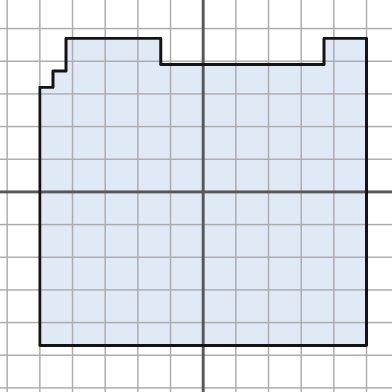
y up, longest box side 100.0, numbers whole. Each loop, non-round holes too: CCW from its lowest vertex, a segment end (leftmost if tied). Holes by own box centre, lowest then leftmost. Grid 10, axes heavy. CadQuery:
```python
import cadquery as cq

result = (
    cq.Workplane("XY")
    .moveTo(-50.0, -47.0)
    .lineTo(50.0, -47.0)
    .lineTo(50.0, 47.0)
    .lineTo(37.0, 47.0)
    .lineTo(37.0, 39.0)
    .lineTo(-13.0, 39.0)
    .lineTo(-13.0, 47.0)
    .lineTo(-42.0, 47.0)
    .lineTo(-42.0, 37.0)
    .lineTo(-46.0, 37.0)
    .lineTo(-46.0, 32.0)
    .lineTo(-50.0, 32.0)
    .close()
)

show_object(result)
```